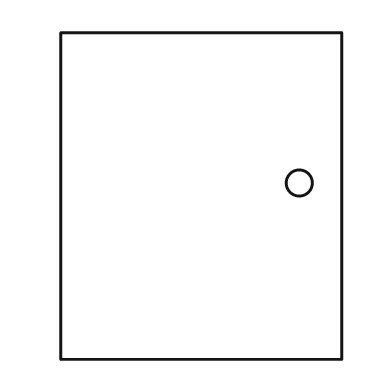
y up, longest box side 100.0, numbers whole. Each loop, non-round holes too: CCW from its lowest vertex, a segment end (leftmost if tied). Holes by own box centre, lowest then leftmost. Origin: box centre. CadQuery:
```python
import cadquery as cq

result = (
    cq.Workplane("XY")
    .moveTo(-43.0, -50.0)
    .lineTo(43.0, -50.0)
    .lineTo(43.0, 50.0)
    .lineTo(-43.0, 50.0)
    .close()
    .moveTo(30.0, 4.0)
    .circle(4.0)
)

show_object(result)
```